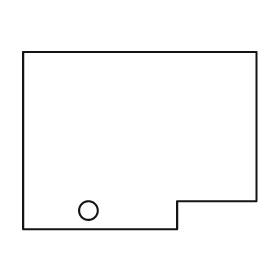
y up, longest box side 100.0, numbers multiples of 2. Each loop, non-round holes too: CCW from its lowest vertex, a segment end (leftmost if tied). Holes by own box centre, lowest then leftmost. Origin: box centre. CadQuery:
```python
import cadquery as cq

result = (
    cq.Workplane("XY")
    .moveTo(-50.0, -38.0)
    .lineTo(16.0, -38.0)
    .lineTo(16.0, -26.0)
    .lineTo(50.0, -26.0)
    .lineTo(50.0, 38.0)
    .lineTo(-50.0, 38.0)
    .close()
    .moveTo(-22.0, -30.0)
    .circle(4.0)
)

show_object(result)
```